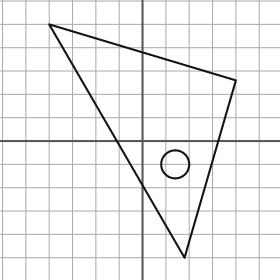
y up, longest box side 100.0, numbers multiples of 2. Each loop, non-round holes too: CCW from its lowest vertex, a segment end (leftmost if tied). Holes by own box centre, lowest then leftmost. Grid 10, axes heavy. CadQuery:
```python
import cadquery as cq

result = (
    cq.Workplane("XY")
    .moveTo(18.0, -50.0)
    .lineTo(40.0, 26.0)
    .lineTo(-40.0, 50.0)
    .close()
    .moveTo(14.0, -10.0)
    .circle(6.0)
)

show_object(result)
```